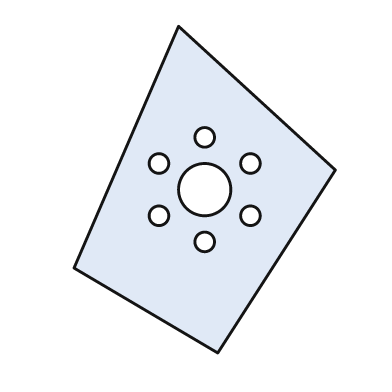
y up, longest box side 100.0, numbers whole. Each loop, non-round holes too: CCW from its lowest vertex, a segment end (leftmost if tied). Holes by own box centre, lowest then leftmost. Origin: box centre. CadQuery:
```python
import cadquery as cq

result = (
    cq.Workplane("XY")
    .moveTo(4.0, -50.0)
    .lineTo(40.0, 6.0)
    .lineTo(-8.0, 50.0)
    .lineTo(-40.0, -24.0)
    .close()
    .moveTo(0.0, -16.0)
    .circle(3.0)
    .moveTo(-14.0, -8.0)
    .circle(3.0)
    .moveTo(14.0, -8.0)
    .circle(3.0)
    .moveTo(0.0, 0.0)
    .circle(8.0)
    .moveTo(-14.0, 8.0)
    .circle(3.0)
    .moveTo(14.0, 8.0)
    .circle(3.0)
    .moveTo(0.0, 16.0)
    .circle(3.0)
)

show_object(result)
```